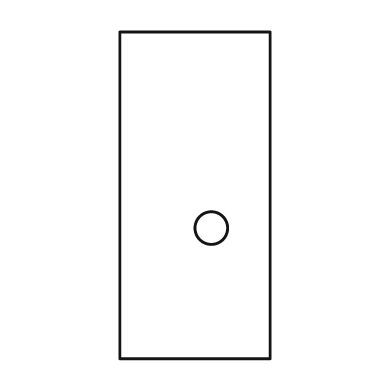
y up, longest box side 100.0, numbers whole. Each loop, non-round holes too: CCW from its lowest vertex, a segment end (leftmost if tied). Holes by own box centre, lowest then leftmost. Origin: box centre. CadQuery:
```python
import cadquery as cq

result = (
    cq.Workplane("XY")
    .moveTo(-23.0, -50.0)
    .lineTo(23.0, -50.0)
    .lineTo(23.0, 50.0)
    .lineTo(-23.0, 50.0)
    .close()
    .moveTo(5.0, -10.0)
    .circle(5.0)
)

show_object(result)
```